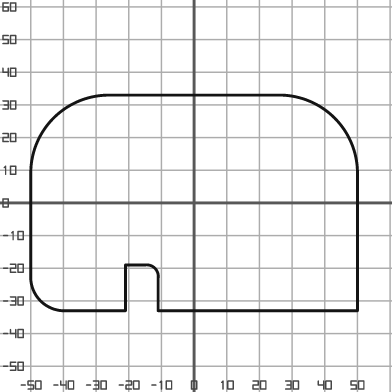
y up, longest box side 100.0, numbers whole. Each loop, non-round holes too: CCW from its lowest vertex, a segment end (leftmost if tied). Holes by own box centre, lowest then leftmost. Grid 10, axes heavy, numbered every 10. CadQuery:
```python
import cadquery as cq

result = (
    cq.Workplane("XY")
    .moveTo(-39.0, -33.0)
    .lineTo(-21.0, -33.0)
    .lineTo(-21.0, -19.0)
    .lineTo(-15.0, -19.0)
    .threePointArc((-12.0, -20.0), (-11.0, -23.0))
    .lineTo(-11.0, -33.0)
    .lineTo(50.0, -33.0)
    .lineTo(50.0, 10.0)
    .threePointArc((43.0, 26.0), (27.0, 33.0))
    .lineTo(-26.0, 33.0)
    .threePointArc((-43.0, 26.0), (-50.0, 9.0))
    .lineTo(-50.0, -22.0)
    .threePointArc((-47.0, -30.0), (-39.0, -33.0))
    .close()
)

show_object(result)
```